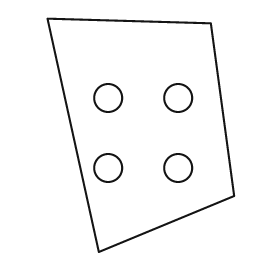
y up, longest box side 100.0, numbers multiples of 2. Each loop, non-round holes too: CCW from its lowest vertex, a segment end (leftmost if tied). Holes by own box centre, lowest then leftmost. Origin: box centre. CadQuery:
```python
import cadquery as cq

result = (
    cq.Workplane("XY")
    .moveTo(-18.0, -50.0)
    .lineTo(40.0, -26.0)
    .lineTo(30.0, 48.0)
    .lineTo(-40.0, 50.0)
    .close()
    .moveTo(-14.0, -14.0)
    .circle(6.0)
    .moveTo(16.0, -14.0)
    .circle(6.0)
    .moveTo(-14.0, 16.0)
    .circle(6.0)
    .moveTo(16.0, 16.0)
    .circle(6.0)
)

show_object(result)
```